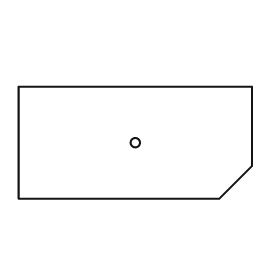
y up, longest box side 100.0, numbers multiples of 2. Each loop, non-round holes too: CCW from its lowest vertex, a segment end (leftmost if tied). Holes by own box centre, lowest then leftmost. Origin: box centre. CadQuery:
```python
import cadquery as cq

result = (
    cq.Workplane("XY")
    .moveTo(-50.0, -24.0)
    .lineTo(36.0, -24.0)
    .lineTo(50.0, -10.0)
    .lineTo(50.0, 24.0)
    .lineTo(-50.0, 24.0)
    .close()
    .moveTo(0.0, 0.0)
    .circle(2.0)
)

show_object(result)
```